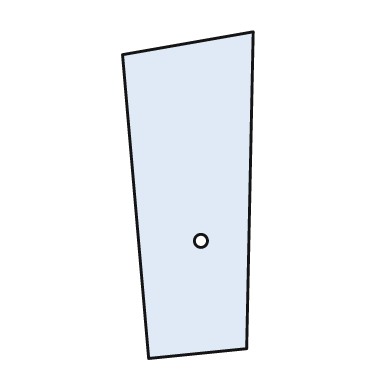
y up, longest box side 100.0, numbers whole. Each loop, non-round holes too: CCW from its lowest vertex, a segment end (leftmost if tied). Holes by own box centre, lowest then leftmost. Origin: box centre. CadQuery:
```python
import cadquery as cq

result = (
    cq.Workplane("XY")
    .moveTo(-12.0, -50.0)
    .lineTo(18.0, -47.0)
    .lineTo(20.0, 50.0)
    .lineTo(-20.0, 43.0)
    .close()
    .moveTo(4.0, -14.0)
    .circle(2.0)
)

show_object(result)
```